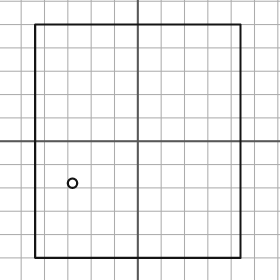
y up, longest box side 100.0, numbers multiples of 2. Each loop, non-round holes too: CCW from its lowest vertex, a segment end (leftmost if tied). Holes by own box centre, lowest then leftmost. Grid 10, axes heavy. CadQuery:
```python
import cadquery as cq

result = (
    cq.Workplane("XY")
    .moveTo(-44.0, -50.0)
    .lineTo(44.0, -50.0)
    .lineTo(44.0, 50.0)
    .lineTo(-44.0, 50.0)
    .close()
    .moveTo(-28.0, -18.0)
    .circle(2.0)
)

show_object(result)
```